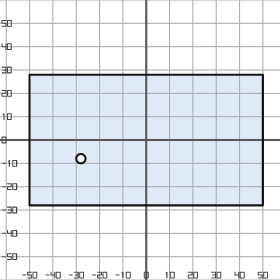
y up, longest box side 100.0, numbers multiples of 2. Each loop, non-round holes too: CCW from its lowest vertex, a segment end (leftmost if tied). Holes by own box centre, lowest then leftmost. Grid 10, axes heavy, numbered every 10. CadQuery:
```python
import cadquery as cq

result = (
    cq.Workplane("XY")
    .moveTo(-50.0, -28.0)
    .lineTo(50.0, -28.0)
    .lineTo(50.0, 28.0)
    .lineTo(-50.0, 28.0)
    .close()
    .moveTo(-28.0, -8.0)
    .circle(2.0)
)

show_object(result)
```